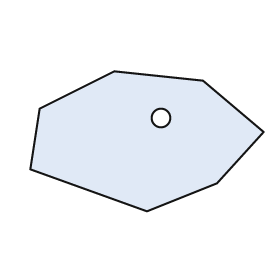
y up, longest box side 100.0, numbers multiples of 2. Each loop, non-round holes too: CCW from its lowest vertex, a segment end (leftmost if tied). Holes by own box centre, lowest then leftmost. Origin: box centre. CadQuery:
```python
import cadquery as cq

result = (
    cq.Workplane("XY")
    .moveTo(0.0, -30.0)
    .lineTo(30.0, -18.0)
    .lineTo(50.0, 4.0)
    .lineTo(24.0, 26.0)
    .lineTo(-14.0, 30.0)
    .lineTo(-46.0, 14.0)
    .lineTo(-50.0, -12.0)
    .close()
    .moveTo(6.0, 10.0)
    .circle(4.0)
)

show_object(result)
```